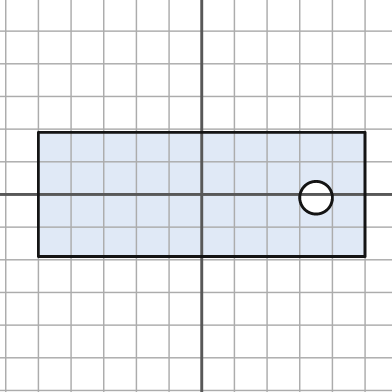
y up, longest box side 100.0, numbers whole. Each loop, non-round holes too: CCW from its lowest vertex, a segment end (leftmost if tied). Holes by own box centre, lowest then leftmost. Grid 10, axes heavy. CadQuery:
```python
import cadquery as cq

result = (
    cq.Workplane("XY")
    .moveTo(-50.0, -19.0)
    .lineTo(50.0, -19.0)
    .lineTo(50.0, 19.0)
    .lineTo(-50.0, 19.0)
    .close()
    .moveTo(35.0, -1.0)
    .circle(5.0)
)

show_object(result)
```